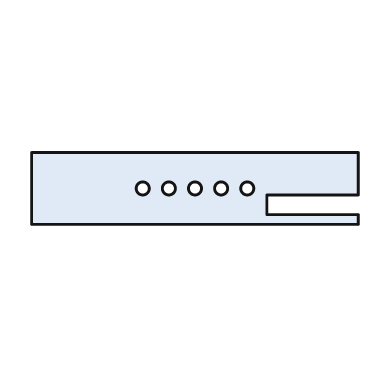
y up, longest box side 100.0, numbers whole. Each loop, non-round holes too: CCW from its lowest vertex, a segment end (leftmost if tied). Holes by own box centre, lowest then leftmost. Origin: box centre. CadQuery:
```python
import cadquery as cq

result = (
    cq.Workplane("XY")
    .moveTo(-50.0, -11.0)
    .lineTo(50.0, -11.0)
    .lineTo(50.0, -8.0)
    .lineTo(22.0, -8.0)
    .lineTo(22.0, -2.0)
    .lineTo(50.0, -2.0)
    .lineTo(50.0, 11.0)
    .lineTo(-50.0, 11.0)
    .close()
    .moveTo(-16.0, 0.0)
    .circle(2.0)
    .moveTo(-8.0, 0.0)
    .circle(2.0)
    .moveTo(0.0, 0.0)
    .circle(2.0)
    .moveTo(8.0, 0.0)
    .circle(2.0)
    .moveTo(16.0, 0.0)
    .circle(2.0)
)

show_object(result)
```